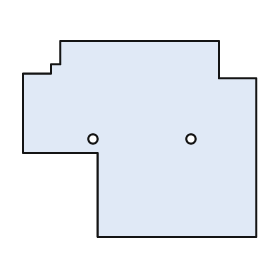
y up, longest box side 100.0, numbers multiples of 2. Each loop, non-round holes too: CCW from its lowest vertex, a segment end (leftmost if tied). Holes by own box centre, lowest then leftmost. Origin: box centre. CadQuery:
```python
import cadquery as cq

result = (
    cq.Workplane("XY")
    .moveTo(-18.0, -42.0)
    .lineTo(50.0, -42.0)
    .lineTo(50.0, 26.0)
    .lineTo(34.0, 26.0)
    .lineTo(34.0, 42.0)
    .lineTo(-34.0, 42.0)
    .lineTo(-34.0, 32.0)
    .lineTo(-38.0, 32.0)
    .lineTo(-38.0, 28.0)
    .lineTo(-50.0, 28.0)
    .lineTo(-50.0, -6.0)
    .lineTo(-18.0, -6.0)
    .close()
    .moveTo(-20.0, 0.0)
    .circle(2.0)
    .moveTo(22.0, 0.0)
    .circle(2.0)
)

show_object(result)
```